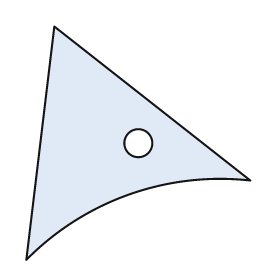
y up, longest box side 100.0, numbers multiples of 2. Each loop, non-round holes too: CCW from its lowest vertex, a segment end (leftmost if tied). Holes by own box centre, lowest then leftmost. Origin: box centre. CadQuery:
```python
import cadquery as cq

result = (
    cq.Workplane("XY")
    .moveTo(-48.0, -50.0)
    .threePointArc((-4.0, -22.0), (48.0, -16.0))
    .lineTo(-36.0, 50.0)
    .close()
    .moveTo(0.0, 0.0)
    .circle(6.0)
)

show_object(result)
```